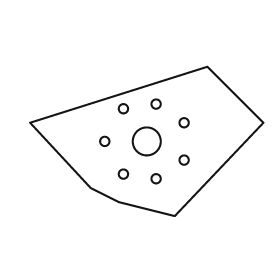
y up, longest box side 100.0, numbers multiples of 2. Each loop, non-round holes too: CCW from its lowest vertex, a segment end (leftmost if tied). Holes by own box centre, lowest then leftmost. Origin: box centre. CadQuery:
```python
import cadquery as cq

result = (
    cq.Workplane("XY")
    .moveTo(12.0, -32.0)
    .lineTo(50.0, 8.0)
    .lineTo(26.0, 32.0)
    .lineTo(-50.0, 8.0)
    .lineTo(-24.0, -20.0)
    .lineTo(-12.0, -26.0)
    .close()
    .moveTo(4.0, -16.0)
    .circle(2.0)
    .moveTo(-10.0, -14.0)
    .circle(2.0)
    .moveTo(16.0, -8.0)
    .circle(2.0)
    .moveTo(-18.0, 0.0)
    .circle(2.0)
    .moveTo(0.0, 0.0)
    .circle(6.0)
    .moveTo(16.0, 8.0)
    .circle(2.0)
    .moveTo(-10.0, 14.0)
    .circle(2.0)
    .moveTo(4.0, 16.0)
    .circle(2.0)
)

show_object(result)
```